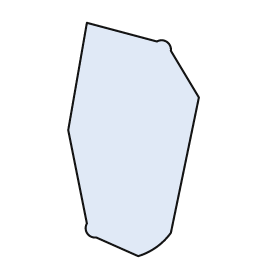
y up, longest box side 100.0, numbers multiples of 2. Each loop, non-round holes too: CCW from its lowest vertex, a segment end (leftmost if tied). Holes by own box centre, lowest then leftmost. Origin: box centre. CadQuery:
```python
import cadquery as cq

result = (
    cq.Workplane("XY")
    .moveTo(2.0, -50.0)
    .threePointArc((10.0, -46.0), (16.0, -40.0))
    .lineTo(28.0, 18.0)
    .lineTo(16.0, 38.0)
    .threePointArc((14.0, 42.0), (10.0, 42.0))
    .lineTo(-20.0, 50.0)
    .lineTo(-28.0, 4.0)
    .lineTo(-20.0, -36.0)
    .threePointArc((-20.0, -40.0), (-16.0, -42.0))
    .close()
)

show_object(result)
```